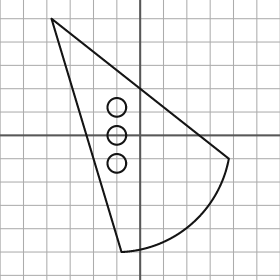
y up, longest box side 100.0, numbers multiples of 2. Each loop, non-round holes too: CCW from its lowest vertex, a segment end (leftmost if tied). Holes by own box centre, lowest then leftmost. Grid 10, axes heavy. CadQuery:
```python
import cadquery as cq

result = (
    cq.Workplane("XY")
    .moveTo(-8.0, -50.0)
    .threePointArc((22.0, -38.0), (38.0, -10.0))
    .lineTo(-38.0, 50.0)
    .close()
    .moveTo(-10.0, -12.0)
    .circle(4.0)
    .moveTo(-10.0, 0.0)
    .circle(4.0)
    .moveTo(-10.0, 12.0)
    .circle(4.0)
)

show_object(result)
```